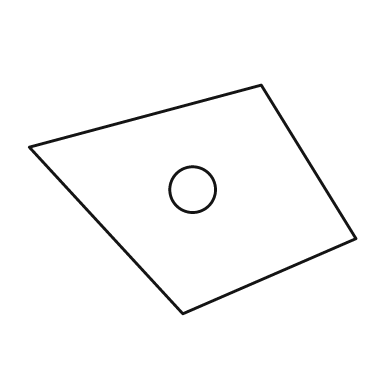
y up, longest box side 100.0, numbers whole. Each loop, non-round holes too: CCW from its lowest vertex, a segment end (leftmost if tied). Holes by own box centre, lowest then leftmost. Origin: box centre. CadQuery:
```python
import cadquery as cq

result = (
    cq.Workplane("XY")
    .moveTo(-3.0, -35.0)
    .lineTo(50.0, -12.0)
    .lineTo(21.0, 35.0)
    .lineTo(-50.0, 16.0)
    .close()
    .moveTo(0.0, 3.0)
    .circle(7.0)
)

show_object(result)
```